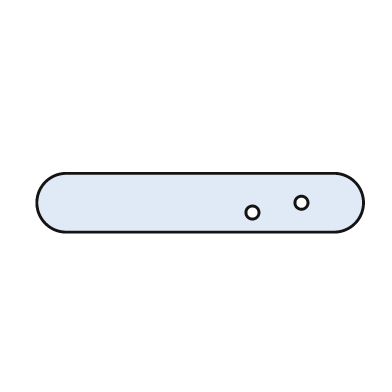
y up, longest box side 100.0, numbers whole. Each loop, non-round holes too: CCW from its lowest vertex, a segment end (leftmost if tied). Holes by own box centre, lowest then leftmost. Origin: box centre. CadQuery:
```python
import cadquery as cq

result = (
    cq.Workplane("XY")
    .moveTo(-41.0, -9.0)
    .lineTo(41.0, -9.0)
    .threePointArc((50.0, 0.0), (41.0, 9.0))
    .lineTo(-41.0, 9.0)
    .threePointArc((-50.0, 0.0), (-41.0, -9.0))
    .close()
    .moveTo(16.0, -3.0)
    .circle(2.0)
    .moveTo(31.0, 0.0)
    .circle(2.0)
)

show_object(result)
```